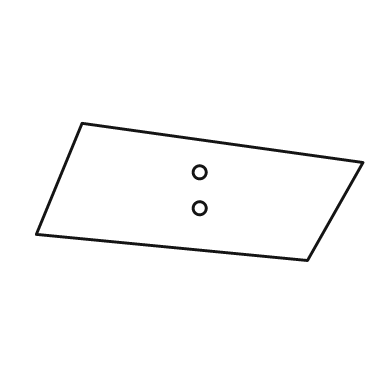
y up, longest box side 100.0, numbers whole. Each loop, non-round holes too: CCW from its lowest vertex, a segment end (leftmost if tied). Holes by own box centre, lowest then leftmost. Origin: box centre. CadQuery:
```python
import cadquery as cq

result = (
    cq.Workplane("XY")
    .moveTo(33.0, -21.0)
    .lineTo(50.0, 9.0)
    .lineTo(-36.0, 21.0)
    .lineTo(-50.0, -13.0)
    .close()
    .moveTo(0.0, -5.0)
    .circle(2.0)
    .moveTo(0.0, 6.0)
    .circle(2.0)
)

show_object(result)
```